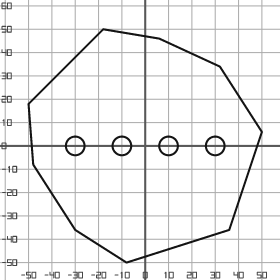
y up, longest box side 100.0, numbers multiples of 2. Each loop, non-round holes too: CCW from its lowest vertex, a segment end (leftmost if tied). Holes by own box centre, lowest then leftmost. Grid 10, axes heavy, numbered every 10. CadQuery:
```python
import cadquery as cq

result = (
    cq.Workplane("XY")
    .moveTo(-8.0, -50.0)
    .lineTo(36.0, -36.0)
    .lineTo(50.0, 6.0)
    .lineTo(32.0, 34.0)
    .lineTo(6.0, 46.0)
    .lineTo(-18.0, 50.0)
    .lineTo(-50.0, 18.0)
    .lineTo(-48.0, -8.0)
    .lineTo(-30.0, -36.0)
    .close()
    .moveTo(-30.0, 0.0)
    .circle(4.0)
    .moveTo(-10.0, 0.0)
    .circle(4.0)
    .moveTo(10.0, 0.0)
    .circle(4.0)
    .moveTo(30.0, 0.0)
    .circle(4.0)
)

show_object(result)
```